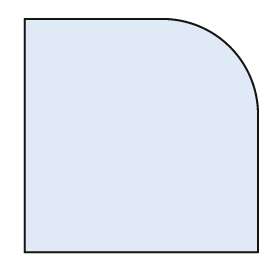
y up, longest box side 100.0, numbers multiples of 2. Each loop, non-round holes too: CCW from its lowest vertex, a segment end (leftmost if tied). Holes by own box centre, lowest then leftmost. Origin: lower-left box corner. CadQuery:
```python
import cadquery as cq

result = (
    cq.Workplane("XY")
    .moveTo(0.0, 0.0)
    .lineTo(100.0, 0.0)
    .lineTo(100.0, 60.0)
    .threePointArc((88.0, 88.0), (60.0, 100.0))
    .lineTo(0.0, 100.0)
    .close()
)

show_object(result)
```